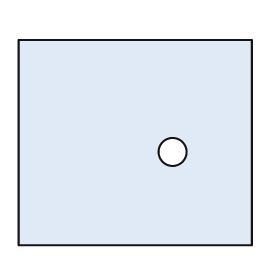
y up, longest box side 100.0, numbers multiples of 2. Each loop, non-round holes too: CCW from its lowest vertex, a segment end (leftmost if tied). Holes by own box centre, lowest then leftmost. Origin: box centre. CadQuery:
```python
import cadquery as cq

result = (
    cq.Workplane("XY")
    .moveTo(-50.0, -44.0)
    .lineTo(50.0, -44.0)
    .lineTo(50.0, 44.0)
    .lineTo(-50.0, 44.0)
    .close()
    .moveTo(16.0, -4.0)
    .circle(6.0)
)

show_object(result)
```